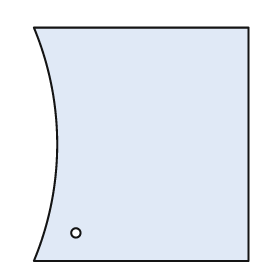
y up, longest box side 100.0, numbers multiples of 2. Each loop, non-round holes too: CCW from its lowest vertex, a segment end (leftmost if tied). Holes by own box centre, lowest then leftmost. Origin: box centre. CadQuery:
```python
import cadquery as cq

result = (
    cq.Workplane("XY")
    .moveTo(-46.0, -50.0)
    .lineTo(46.0, -50.0)
    .lineTo(46.0, 50.0)
    .lineTo(-46.0, 50.0)
    .threePointArc((-36.0, 0.0), (-46.0, -50.0))
    .close()
    .moveTo(-28.0, -38.0)
    .circle(2.0)
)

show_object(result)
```